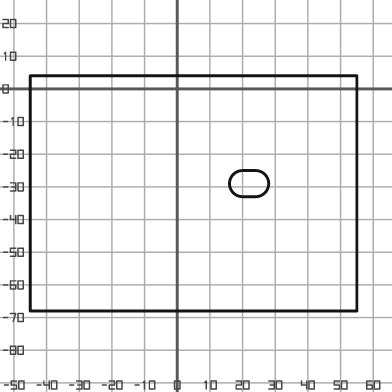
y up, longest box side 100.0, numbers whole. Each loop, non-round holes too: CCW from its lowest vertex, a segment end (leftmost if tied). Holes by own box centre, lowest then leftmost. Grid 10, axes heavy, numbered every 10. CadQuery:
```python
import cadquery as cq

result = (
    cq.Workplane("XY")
    .moveTo(-45.0, -68.0)
    .lineTo(55.0, -68.0)
    .lineTo(55.0, 4.0)
    .lineTo(-45.0, 4.0)
    .close()
    .moveTo(20.0, -33.0)
    .lineTo(24.0, -33.0)
    .threePointArc((28.0, -29.0), (24.0, -25.0))
    .lineTo(20.0, -25.0)
    .threePointArc((16.0, -29.0), (20.0, -33.0))
    .close()
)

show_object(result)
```